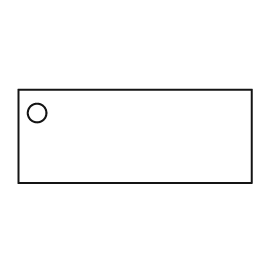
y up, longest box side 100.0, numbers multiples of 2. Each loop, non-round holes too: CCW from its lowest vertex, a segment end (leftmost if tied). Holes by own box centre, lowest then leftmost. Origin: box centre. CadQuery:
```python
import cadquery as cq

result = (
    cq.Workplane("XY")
    .moveTo(-50.0, -20.0)
    .lineTo(50.0, -20.0)
    .lineTo(50.0, 20.0)
    .lineTo(-50.0, 20.0)
    .close()
    .moveTo(-42.0, 10.0)
    .circle(4.0)
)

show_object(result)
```